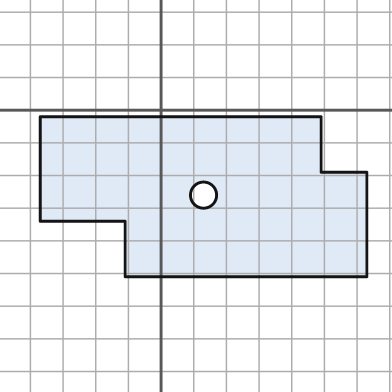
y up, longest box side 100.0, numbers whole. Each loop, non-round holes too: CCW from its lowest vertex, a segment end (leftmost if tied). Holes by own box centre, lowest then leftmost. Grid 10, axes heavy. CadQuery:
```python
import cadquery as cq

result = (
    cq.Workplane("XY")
    .moveTo(-11.0, -51.0)
    .lineTo(63.0, -51.0)
    .lineTo(63.0, -19.0)
    .lineTo(49.0, -19.0)
    .lineTo(49.0, -2.0)
    .lineTo(-37.0, -2.0)
    .lineTo(-37.0, -34.0)
    .lineTo(-11.0, -34.0)
    .close()
    .moveTo(13.0, -26.0)
    .circle(4.0)
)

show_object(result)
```